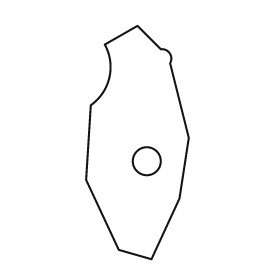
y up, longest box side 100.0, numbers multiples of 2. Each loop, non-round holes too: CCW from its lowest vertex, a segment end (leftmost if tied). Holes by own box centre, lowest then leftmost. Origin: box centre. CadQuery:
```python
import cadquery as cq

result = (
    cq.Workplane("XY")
    .moveTo(6.0, -50.0)
    .lineTo(18.0, -24.0)
    .lineTo(22.0, 2.0)
    .lineTo(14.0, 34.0)
    .threePointArc((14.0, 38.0), (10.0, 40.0))
    .lineTo(0.0, 50.0)
    .lineTo(-14.0, 42.0)
    .threePointArc((-12.0, 28.0), (-20.0, 16.0))
    .lineTo(-22.0, -16.0)
    .lineTo(-8.0, -46.0)
    .close()
    .moveTo(4.0, -8.0)
    .circle(6.0)
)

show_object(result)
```